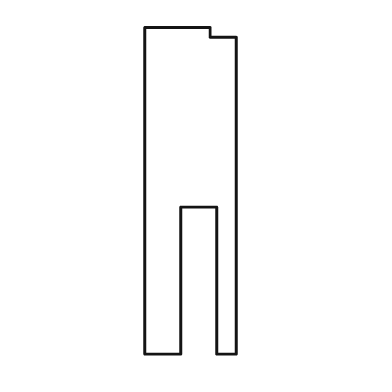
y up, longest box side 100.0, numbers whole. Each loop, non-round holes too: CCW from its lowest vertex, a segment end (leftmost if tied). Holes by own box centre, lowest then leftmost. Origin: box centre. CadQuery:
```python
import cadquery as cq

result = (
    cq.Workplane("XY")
    .moveTo(-14.0, -50.0)
    .lineTo(-3.0, -50.0)
    .lineTo(-3.0, -5.0)
    .lineTo(8.0, -5.0)
    .lineTo(8.0, -50.0)
    .lineTo(14.0, -50.0)
    .lineTo(14.0, 47.0)
    .lineTo(6.0, 47.0)
    .lineTo(6.0, 50.0)
    .lineTo(-14.0, 50.0)
    .close()
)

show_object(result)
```